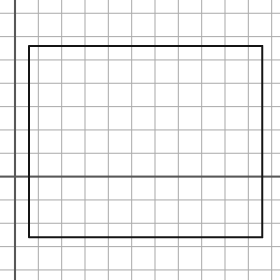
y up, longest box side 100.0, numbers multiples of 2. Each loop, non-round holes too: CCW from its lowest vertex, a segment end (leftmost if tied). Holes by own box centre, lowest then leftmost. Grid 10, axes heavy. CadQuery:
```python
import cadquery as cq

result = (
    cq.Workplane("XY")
    .moveTo(6.0, -26.0)
    .lineTo(106.0, -26.0)
    .lineTo(106.0, 56.0)
    .lineTo(6.0, 56.0)
    .close()
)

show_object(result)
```